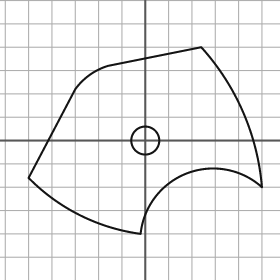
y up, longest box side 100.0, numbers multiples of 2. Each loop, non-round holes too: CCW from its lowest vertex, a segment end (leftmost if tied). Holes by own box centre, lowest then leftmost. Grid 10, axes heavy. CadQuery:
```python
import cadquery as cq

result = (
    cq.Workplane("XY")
    .moveTo(-2.0, -40.0)
    .threePointArc((18.0, -14.0), (50.0, -20.0))
    .threePointArc((42.0, 12.0), (24.0, 40.0))
    .lineTo(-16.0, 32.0)
    .threePointArc((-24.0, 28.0), (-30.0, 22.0))
    .lineTo(-50.0, -16.0)
    .threePointArc((-28.0, -32.0), (-2.0, -40.0))
    .close()
    .moveTo(0.0, 0.0)
    .circle(6.0)
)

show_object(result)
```